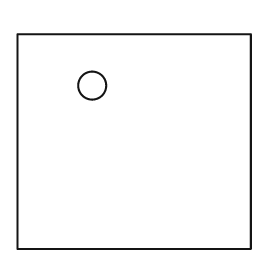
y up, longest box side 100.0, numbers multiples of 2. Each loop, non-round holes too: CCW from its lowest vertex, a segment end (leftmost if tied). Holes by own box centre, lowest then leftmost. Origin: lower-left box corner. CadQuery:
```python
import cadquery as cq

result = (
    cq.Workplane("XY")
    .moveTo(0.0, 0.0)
    .lineTo(100.0, 0.0)
    .lineTo(100.0, 92.0)
    .lineTo(0.0, 92.0)
    .close()
    .moveTo(32.0, 70.0)
    .circle(6.0)
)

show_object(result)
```